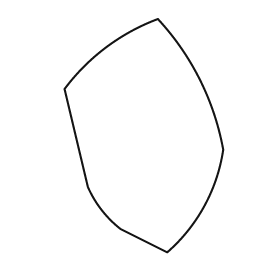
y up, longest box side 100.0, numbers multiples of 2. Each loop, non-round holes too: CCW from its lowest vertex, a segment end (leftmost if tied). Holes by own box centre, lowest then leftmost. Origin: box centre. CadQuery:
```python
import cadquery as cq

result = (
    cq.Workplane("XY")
    .moveTo(10.0, -50.0)
    .threePointArc((26.0, -30.0), (34.0, -6.0))
    .threePointArc((24.0, 24.0), (6.0, 50.0))
    .threePointArc((-16.0, 38.0), (-34.0, 20.0))
    .lineTo(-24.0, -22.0)
    .threePointArc((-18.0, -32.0), (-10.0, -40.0))
    .close()
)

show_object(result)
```